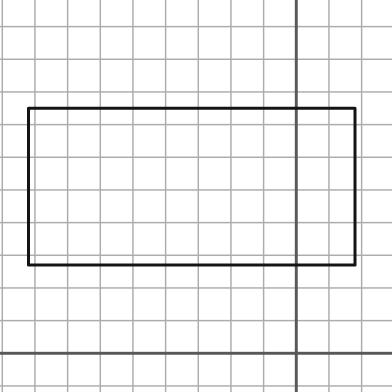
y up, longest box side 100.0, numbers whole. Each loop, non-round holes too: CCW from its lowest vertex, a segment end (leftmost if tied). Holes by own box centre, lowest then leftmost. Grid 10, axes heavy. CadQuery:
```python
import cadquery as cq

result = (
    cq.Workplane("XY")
    .moveTo(-82.0, 27.0)
    .lineTo(18.0, 27.0)
    .lineTo(18.0, 75.0)
    .lineTo(-82.0, 75.0)
    .close()
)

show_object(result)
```